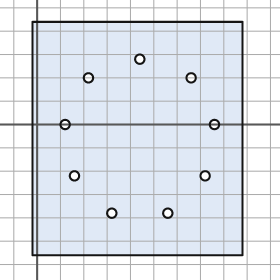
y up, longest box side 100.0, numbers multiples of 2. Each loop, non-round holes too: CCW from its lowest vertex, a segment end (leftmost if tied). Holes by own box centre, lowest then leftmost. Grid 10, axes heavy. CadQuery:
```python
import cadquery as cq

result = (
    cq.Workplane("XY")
    .moveTo(-2.0, -56.0)
    .lineTo(88.0, -56.0)
    .lineTo(88.0, 44.0)
    .lineTo(-2.0, 44.0)
    .close()
    .moveTo(32.0, -38.0)
    .circle(2.0)
    .moveTo(56.0, -38.0)
    .circle(2.0)
    .moveTo(16.0, -22.0)
    .circle(2.0)
    .moveTo(72.0, -22.0)
    .circle(2.0)
    .moveTo(12.0, 0.0)
    .circle(2.0)
    .moveTo(76.0, 0.0)
    .circle(2.0)
    .moveTo(22.0, 20.0)
    .circle(2.0)
    .moveTo(66.0, 20.0)
    .circle(2.0)
    .moveTo(44.0, 28.0)
    .circle(2.0)
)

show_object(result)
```